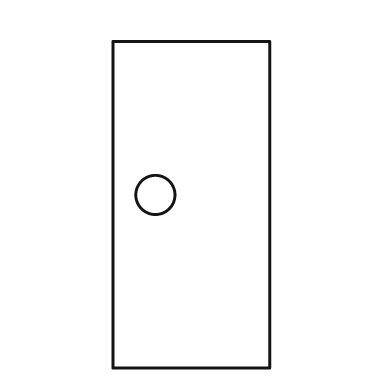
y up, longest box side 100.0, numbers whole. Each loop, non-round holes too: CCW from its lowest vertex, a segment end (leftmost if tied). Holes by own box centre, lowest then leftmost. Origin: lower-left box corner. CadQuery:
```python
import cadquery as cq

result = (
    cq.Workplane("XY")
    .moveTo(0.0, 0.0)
    .lineTo(48.0, 0.0)
    .lineTo(48.0, 100.0)
    .lineTo(0.0, 100.0)
    .close()
    .moveTo(13.0, 53.0)
    .circle(6.0)
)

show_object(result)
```